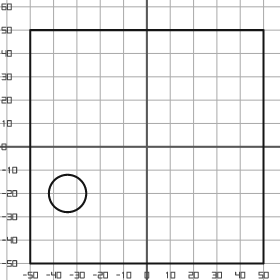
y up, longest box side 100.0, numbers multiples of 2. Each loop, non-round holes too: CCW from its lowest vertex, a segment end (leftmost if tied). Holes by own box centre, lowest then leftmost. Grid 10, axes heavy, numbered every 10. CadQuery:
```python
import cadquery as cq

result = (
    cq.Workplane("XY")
    .moveTo(-50.0, -50.0)
    .lineTo(50.0, -50.0)
    .lineTo(50.0, 50.0)
    .lineTo(-50.0, 50.0)
    .close()
    .moveTo(-34.0, -20.0)
    .circle(8.0)
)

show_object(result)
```